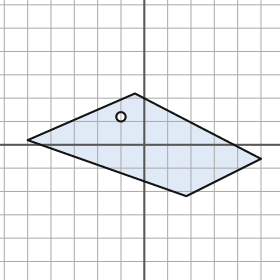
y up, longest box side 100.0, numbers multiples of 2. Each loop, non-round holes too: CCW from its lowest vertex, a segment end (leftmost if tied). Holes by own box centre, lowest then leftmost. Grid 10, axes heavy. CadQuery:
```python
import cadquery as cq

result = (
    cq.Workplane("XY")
    .moveTo(18.0, -22.0)
    .lineTo(50.0, -6.0)
    .lineTo(-4.0, 22.0)
    .lineTo(-50.0, 2.0)
    .close()
    .moveTo(-10.0, 12.0)
    .circle(2.0)
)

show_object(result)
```